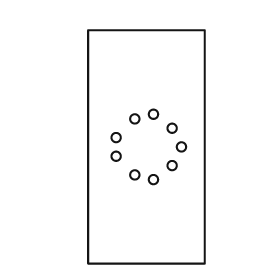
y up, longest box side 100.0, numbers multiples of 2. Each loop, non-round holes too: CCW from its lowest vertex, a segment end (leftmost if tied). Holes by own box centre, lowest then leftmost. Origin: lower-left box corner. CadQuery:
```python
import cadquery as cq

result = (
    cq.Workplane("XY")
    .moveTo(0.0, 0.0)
    .lineTo(50.0, 0.0)
    .lineTo(50.0, 100.0)
    .lineTo(0.0, 100.0)
    .close()
    .moveTo(28.0, 36.0)
    .circle(2.0)
    .moveTo(20.0, 38.0)
    .circle(2.0)
    .moveTo(36.0, 42.0)
    .circle(2.0)
    .moveTo(12.0, 46.0)
    .circle(2.0)
    .moveTo(40.0, 50.0)
    .circle(2.0)
    .moveTo(12.0, 54.0)
    .circle(2.0)
    .moveTo(36.0, 58.0)
    .circle(2.0)
    .moveTo(20.0, 62.0)
    .circle(2.0)
    .moveTo(28.0, 64.0)
    .circle(2.0)
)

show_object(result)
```